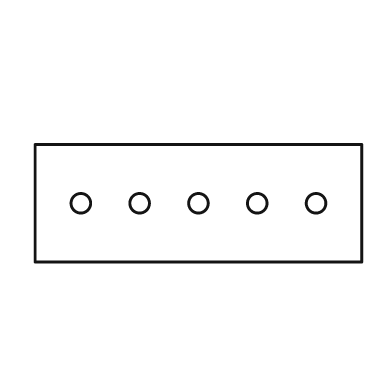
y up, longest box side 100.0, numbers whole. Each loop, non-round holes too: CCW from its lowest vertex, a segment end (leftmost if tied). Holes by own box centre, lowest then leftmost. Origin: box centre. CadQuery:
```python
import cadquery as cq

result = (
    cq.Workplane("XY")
    .moveTo(-50.0, -18.0)
    .lineTo(50.0, -18.0)
    .lineTo(50.0, 18.0)
    .lineTo(-50.0, 18.0)
    .close()
    .moveTo(-36.0, 0.0)
    .circle(3.0)
    .moveTo(-18.0, 0.0)
    .circle(3.0)
    .moveTo(0.0, 0.0)
    .circle(3.0)
    .moveTo(18.0, 0.0)
    .circle(3.0)
    .moveTo(36.0, 0.0)
    .circle(3.0)
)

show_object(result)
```